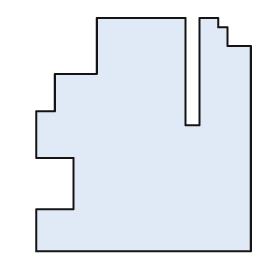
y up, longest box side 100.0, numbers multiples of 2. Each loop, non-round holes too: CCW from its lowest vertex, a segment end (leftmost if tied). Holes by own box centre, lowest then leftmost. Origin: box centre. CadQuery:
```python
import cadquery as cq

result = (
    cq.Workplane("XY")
    .moveTo(-46.0, -50.0)
    .lineTo(46.0, -50.0)
    .lineTo(46.0, 38.0)
    .lineTo(36.0, 38.0)
    .lineTo(36.0, 46.0)
    .lineTo(32.0, 46.0)
    .lineTo(32.0, 50.0)
    .lineTo(24.0, 50.0)
    .lineTo(24.0, 4.0)
    .lineTo(18.0, 4.0)
    .lineTo(18.0, 50.0)
    .lineTo(-20.0, 50.0)
    .lineTo(-20.0, 26.0)
    .lineTo(-38.0, 26.0)
    .lineTo(-38.0, 10.0)
    .lineTo(-46.0, 10.0)
    .lineTo(-46.0, -10.0)
    .lineTo(-30.0, -10.0)
    .lineTo(-30.0, -32.0)
    .lineTo(-46.0, -32.0)
    .close()
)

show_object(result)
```